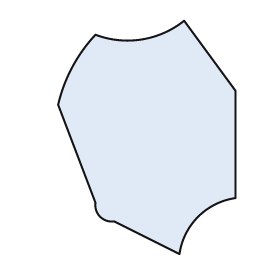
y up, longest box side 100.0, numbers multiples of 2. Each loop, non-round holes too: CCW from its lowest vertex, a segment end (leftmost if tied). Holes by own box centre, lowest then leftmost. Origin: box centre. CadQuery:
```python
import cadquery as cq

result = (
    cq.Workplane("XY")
    .moveTo(14.0, -50.0)
    .threePointArc((22.0, -34.0), (38.0, -26.0))
    .lineTo(38.0, 20.0)
    .lineTo(16.0, 50.0)
    .threePointArc((-2.0, 42.0), (-22.0, 44.0))
    .threePointArc((-32.0, 30.0), (-38.0, 14.0))
    .lineTo(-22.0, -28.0)
    .threePointArc((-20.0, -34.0), (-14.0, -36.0))
    .close()
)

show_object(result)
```